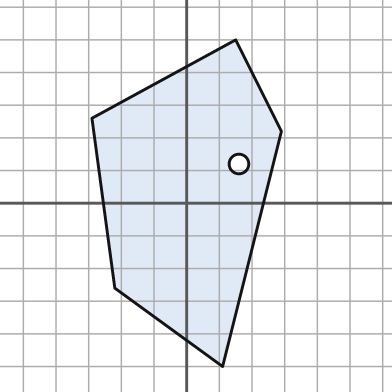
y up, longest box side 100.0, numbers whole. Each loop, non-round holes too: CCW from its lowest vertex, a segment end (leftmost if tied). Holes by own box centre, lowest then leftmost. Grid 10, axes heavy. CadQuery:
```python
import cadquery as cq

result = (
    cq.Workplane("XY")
    .moveTo(11.0, -50.0)
    .lineTo(29.0, 22.0)
    .lineTo(15.0, 50.0)
    .lineTo(-29.0, 26.0)
    .lineTo(-22.0, -26.0)
    .close()
    .moveTo(16.0, 12.0)
    .circle(3.0)
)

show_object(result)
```